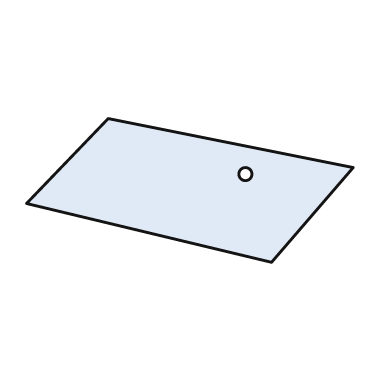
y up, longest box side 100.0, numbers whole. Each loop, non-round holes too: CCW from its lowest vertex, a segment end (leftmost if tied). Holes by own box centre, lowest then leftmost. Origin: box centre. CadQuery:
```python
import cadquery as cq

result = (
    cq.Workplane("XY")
    .moveTo(25.0, -22.0)
    .lineTo(50.0, 7.0)
    .lineTo(-25.0, 22.0)
    .lineTo(-50.0, -4.0)
    .close()
    .moveTo(17.0, 5.0)
    .circle(2.0)
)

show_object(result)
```